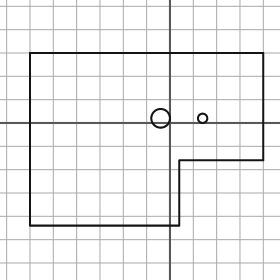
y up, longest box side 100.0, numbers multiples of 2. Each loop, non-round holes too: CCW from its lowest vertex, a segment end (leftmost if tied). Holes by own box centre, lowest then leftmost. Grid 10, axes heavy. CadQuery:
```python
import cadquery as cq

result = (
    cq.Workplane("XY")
    .moveTo(-60.0, -44.0)
    .lineTo(4.0, -44.0)
    .lineTo(4.0, -16.0)
    .lineTo(40.0, -16.0)
    .lineTo(40.0, 30.0)
    .lineTo(-60.0, 30.0)
    .close()
    .moveTo(-4.0, 2.0)
    .circle(4.0)
    .moveTo(14.0, 2.0)
    .circle(2.0)
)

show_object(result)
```